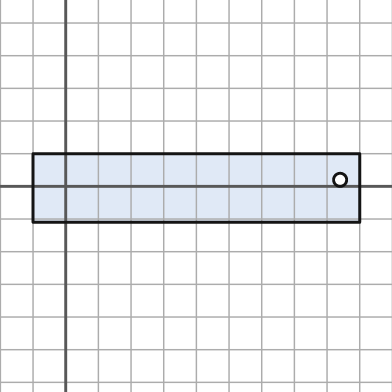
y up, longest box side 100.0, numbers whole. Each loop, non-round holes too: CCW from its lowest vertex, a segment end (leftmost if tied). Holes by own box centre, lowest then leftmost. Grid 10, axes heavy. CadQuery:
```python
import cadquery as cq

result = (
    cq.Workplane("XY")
    .moveTo(-10.0, -11.0)
    .lineTo(90.0, -11.0)
    .lineTo(90.0, 10.0)
    .lineTo(-10.0, 10.0)
    .close()
    .moveTo(84.0, 2.0)
    .circle(2.0)
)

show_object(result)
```